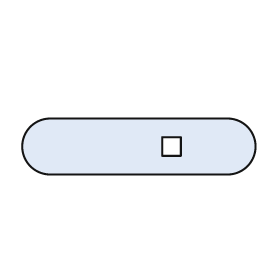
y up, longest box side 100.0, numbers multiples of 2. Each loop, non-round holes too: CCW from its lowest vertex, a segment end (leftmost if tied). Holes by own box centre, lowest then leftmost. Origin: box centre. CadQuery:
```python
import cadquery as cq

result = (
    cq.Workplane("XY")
    .moveTo(-38.0, -12.0)
    .lineTo(38.0, -12.0)
    .threePointArc((50.0, 0.0), (38.0, 12.0))
    .lineTo(-38.0, 12.0)
    .threePointArc((-50.0, 0.0), (-38.0, -12.0))
    .close()
    .moveTo(10.0, -4.0)
    .lineTo(18.0, -4.0)
    .lineTo(18.0, 4.0)
    .lineTo(10.0, 4.0)
    .close()
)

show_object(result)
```